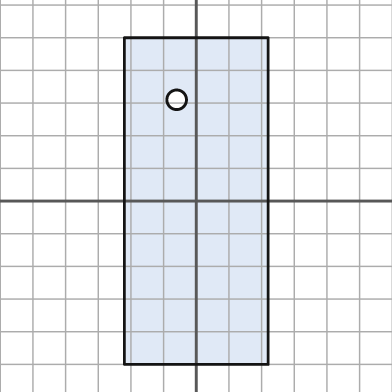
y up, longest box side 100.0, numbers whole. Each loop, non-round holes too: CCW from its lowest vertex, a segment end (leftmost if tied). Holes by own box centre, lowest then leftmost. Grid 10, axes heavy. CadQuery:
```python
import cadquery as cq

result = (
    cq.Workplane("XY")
    .moveTo(-22.0, -50.0)
    .lineTo(22.0, -50.0)
    .lineTo(22.0, 50.0)
    .lineTo(-22.0, 50.0)
    .close()
    .moveTo(-6.0, 31.0)
    .circle(3.0)
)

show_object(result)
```